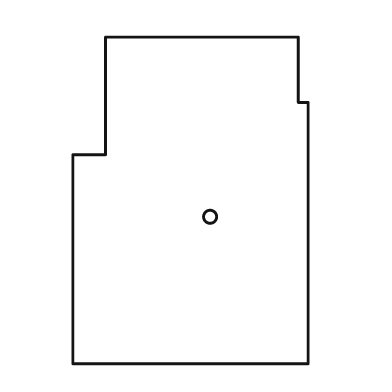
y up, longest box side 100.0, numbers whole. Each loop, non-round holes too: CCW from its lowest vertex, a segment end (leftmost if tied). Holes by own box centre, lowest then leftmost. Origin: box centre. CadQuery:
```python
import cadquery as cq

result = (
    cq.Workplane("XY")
    .moveTo(-36.0, -50.0)
    .lineTo(36.0, -50.0)
    .lineTo(36.0, 30.0)
    .lineTo(33.0, 30.0)
    .lineTo(33.0, 50.0)
    .lineTo(-26.0, 50.0)
    .lineTo(-26.0, 14.0)
    .lineTo(-36.0, 14.0)
    .close()
    .moveTo(6.0, -5.0)
    .circle(2.0)
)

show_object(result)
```